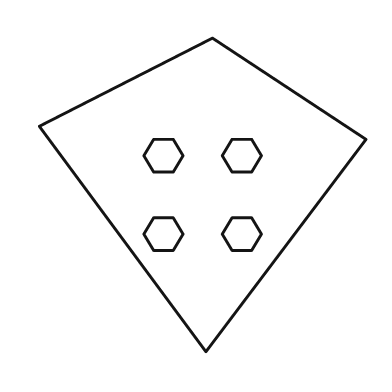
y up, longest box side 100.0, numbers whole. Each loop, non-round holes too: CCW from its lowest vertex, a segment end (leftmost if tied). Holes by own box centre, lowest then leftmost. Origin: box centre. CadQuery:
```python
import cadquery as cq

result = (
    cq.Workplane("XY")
    .moveTo(1.0, -48.0)
    .lineTo(50.0, 17.0)
    .lineTo(3.0, 48.0)
    .lineTo(-50.0, 21.0)
    .close()
    .moveTo(-15.0, -17.0)
    .lineTo(-9.0, -17.0)
    .lineTo(-6.0, -12.0)
    .lineTo(-9.0, -7.0)
    .lineTo(-15.0, -7.0)
    .lineTo(-18.0, -12.0)
    .close()
    .moveTo(9.0, -17.0)
    .lineTo(15.0, -17.0)
    .lineTo(18.0, -12.0)
    .lineTo(15.0, -7.0)
    .lineTo(9.0, -7.0)
    .lineTo(6.0, -12.0)
    .close()
    .moveTo(-15.0, 7.0)
    .lineTo(-9.0, 7.0)
    .lineTo(-6.0, 12.0)
    .lineTo(-9.0, 17.0)
    .lineTo(-15.0, 17.0)
    .lineTo(-18.0, 12.0)
    .close()
    .moveTo(9.0, 7.0)
    .lineTo(15.0, 7.0)
    .lineTo(18.0, 12.0)
    .lineTo(15.0, 17.0)
    .lineTo(9.0, 17.0)
    .lineTo(6.0, 12.0)
    .close()
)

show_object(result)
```